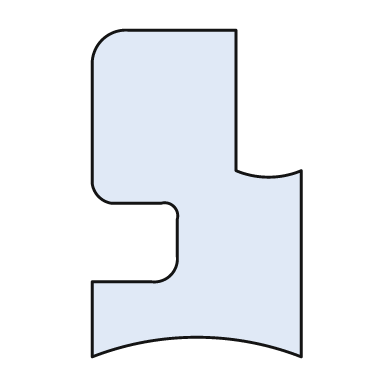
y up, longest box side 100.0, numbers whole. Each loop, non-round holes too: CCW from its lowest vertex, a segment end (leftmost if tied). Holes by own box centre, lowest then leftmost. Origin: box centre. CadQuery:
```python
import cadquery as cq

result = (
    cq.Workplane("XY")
    .moveTo(-32.0, -50.0)
    .threePointArc((0.0, -44.0), (32.0, -50.0))
    .lineTo(32.0, 7.0)
    .threePointArc((22.0, 5.0), (12.0, 7.0))
    .lineTo(12.0, 50.0)
    .lineTo(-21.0, 50.0)
    .threePointArc((-29.0, 47.0), (-32.0, 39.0))
    .lineTo(-32.0, 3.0)
    .threePointArc((-30.0, -1.0), (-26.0, -3.0))
    .lineTo(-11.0, -3.0)
    .threePointArc((-7.0, -4.0), (-6.0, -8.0))
    .lineTo(-6.0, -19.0)
    .threePointArc((-8.0, -25.0), (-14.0, -27.0))
    .lineTo(-32.0, -27.0)
    .close()
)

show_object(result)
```